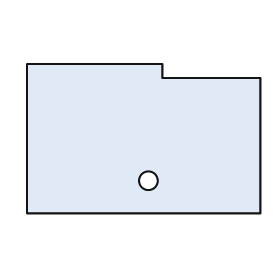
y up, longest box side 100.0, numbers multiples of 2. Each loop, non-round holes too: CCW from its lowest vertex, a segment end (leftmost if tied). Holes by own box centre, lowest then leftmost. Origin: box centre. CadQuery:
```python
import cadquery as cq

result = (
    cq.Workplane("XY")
    .moveTo(-50.0, -32.0)
    .lineTo(50.0, -32.0)
    .lineTo(50.0, 26.0)
    .lineTo(8.0, 26.0)
    .lineTo(8.0, 32.0)
    .lineTo(-50.0, 32.0)
    .close()
    .moveTo(2.0, -18.0)
    .circle(4.0)
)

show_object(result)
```